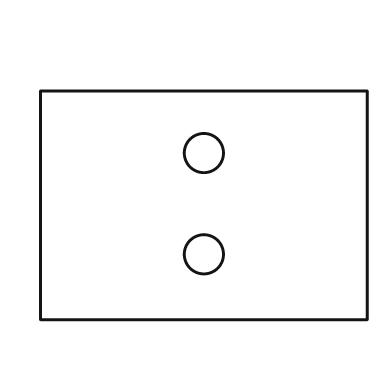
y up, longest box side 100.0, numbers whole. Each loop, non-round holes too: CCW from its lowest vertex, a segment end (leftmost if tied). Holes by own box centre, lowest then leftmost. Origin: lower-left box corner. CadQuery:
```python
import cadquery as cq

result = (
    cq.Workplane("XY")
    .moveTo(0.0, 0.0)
    .lineTo(100.0, 0.0)
    .lineTo(100.0, 70.0)
    .lineTo(0.0, 70.0)
    .close()
    .moveTo(50.0, 20.0)
    .circle(6.0)
    .moveTo(50.0, 51.0)
    .circle(6.0)
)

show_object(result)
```